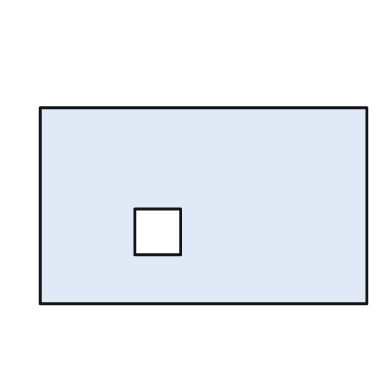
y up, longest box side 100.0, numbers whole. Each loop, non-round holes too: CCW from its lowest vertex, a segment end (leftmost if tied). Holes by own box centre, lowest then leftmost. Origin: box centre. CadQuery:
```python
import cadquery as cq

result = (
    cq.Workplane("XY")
    .moveTo(-50.0, -30.0)
    .lineTo(50.0, -30.0)
    .lineTo(50.0, 30.0)
    .lineTo(-50.0, 30.0)
    .close()
    .moveTo(-21.0, -15.0)
    .lineTo(-7.0, -15.0)
    .lineTo(-7.0, -1.0)
    .lineTo(-21.0, -1.0)
    .close()
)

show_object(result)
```